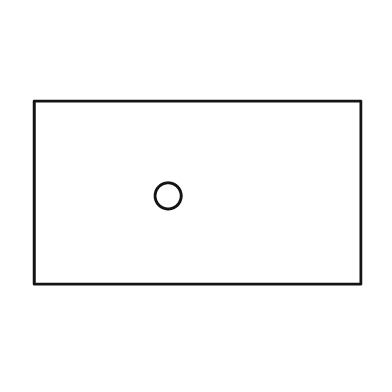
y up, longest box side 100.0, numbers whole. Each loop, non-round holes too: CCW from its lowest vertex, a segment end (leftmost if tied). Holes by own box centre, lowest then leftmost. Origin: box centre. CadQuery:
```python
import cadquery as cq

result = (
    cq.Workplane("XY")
    .moveTo(-50.0, -28.0)
    .lineTo(50.0, -28.0)
    .lineTo(50.0, 28.0)
    .lineTo(-50.0, 28.0)
    .close()
    .moveTo(-9.0, -1.0)
    .circle(4.0)
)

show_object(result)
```